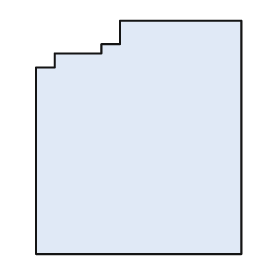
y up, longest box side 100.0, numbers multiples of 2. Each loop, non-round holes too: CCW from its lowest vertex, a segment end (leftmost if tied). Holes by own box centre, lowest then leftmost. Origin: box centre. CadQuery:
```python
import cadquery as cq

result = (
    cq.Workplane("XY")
    .moveTo(-44.0, -50.0)
    .lineTo(44.0, -50.0)
    .lineTo(44.0, 50.0)
    .lineTo(-8.0, 50.0)
    .lineTo(-8.0, 40.0)
    .lineTo(-16.0, 40.0)
    .lineTo(-16.0, 36.0)
    .lineTo(-36.0, 36.0)
    .lineTo(-36.0, 30.0)
    .lineTo(-44.0, 30.0)
    .close()
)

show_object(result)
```